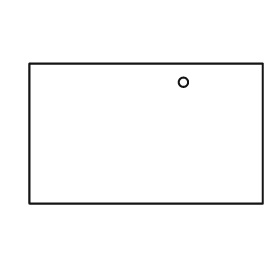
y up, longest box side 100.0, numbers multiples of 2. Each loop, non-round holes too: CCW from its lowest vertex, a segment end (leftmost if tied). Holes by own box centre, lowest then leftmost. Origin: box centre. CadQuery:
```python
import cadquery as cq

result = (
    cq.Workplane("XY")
    .moveTo(-50.0, -30.0)
    .lineTo(50.0, -30.0)
    .lineTo(50.0, 30.0)
    .lineTo(-50.0, 30.0)
    .close()
    .moveTo(16.0, 22.0)
    .circle(2.0)
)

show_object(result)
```